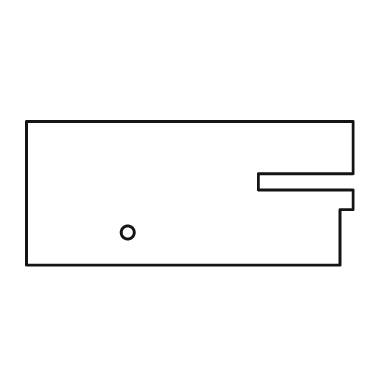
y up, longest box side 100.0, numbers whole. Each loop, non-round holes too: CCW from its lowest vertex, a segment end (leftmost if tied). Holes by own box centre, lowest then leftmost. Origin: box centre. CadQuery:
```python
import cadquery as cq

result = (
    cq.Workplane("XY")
    .moveTo(-50.0, -22.0)
    .lineTo(46.0, -22.0)
    .lineTo(46.0, -5.0)
    .lineTo(50.0, -5.0)
    .lineTo(50.0, 1.0)
    .lineTo(21.0, 1.0)
    .lineTo(21.0, 6.0)
    .lineTo(50.0, 6.0)
    .lineTo(50.0, 22.0)
    .lineTo(-50.0, 22.0)
    .close()
    .moveTo(-19.0, -12.0)
    .circle(2.0)
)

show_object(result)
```